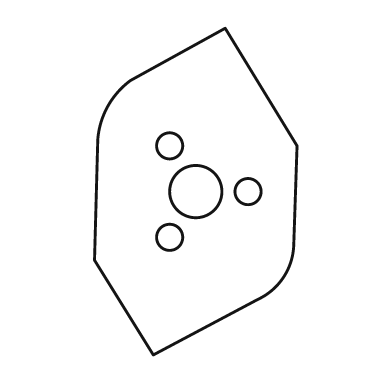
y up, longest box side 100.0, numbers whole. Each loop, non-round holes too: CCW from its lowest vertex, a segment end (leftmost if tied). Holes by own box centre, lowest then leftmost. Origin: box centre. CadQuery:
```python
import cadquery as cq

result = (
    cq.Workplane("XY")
    .moveTo(-13.0, -50.0)
    .lineTo(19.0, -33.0)
    .threePointArc((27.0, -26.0), (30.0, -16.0))
    .lineTo(31.0, 14.0)
    .lineTo(9.0, 50.0)
    .lineTo(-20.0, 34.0)
    .threePointArc((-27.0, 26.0), (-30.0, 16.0))
    .lineTo(-31.0, -21.0)
    .close()
    .moveTo(-8.0, -14.0)
    .circle(4.0)
    .moveTo(0.0, 0.0)
    .circle(8.0)
    .moveTo(16.0, 0.0)
    .circle(4.0)
    .moveTo(-8.0, 14.0)
    .circle(4.0)
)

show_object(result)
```